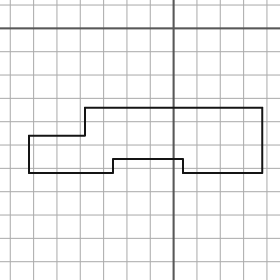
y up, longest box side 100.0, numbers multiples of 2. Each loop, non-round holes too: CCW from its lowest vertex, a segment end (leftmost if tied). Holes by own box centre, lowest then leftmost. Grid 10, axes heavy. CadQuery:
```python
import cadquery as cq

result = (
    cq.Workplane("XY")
    .moveTo(-62.0, -62.0)
    .lineTo(-26.0, -62.0)
    .lineTo(-26.0, -56.0)
    .lineTo(4.0, -56.0)
    .lineTo(4.0, -62.0)
    .lineTo(38.0, -62.0)
    .lineTo(38.0, -34.0)
    .lineTo(-38.0, -34.0)
    .lineTo(-38.0, -46.0)
    .lineTo(-62.0, -46.0)
    .close()
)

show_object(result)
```